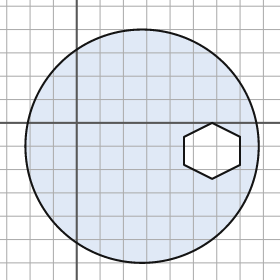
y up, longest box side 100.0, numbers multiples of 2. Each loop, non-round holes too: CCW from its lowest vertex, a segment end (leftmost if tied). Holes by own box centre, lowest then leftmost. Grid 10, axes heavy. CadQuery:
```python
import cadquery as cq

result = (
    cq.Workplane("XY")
    .moveTo(28.0, -10.0)
    .circle(50.0)
    .moveTo(58.0, -24.0)
    .lineTo(70.0, -18.0)
    .lineTo(70.0, -6.0)
    .lineTo(58.0, 0.0)
    .lineTo(46.0, -6.0)
    .lineTo(46.0, -18.0)
    .close()
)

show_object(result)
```